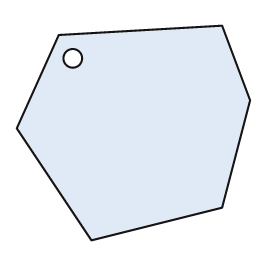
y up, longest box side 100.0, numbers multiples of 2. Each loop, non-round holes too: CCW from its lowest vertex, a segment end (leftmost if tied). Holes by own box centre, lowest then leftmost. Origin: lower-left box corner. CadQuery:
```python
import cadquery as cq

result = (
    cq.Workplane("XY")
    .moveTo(32.0, 0.0)
    .lineTo(88.0, 14.0)
    .lineTo(100.0, 60.0)
    .lineTo(88.0, 92.0)
    .lineTo(18.0, 88.0)
    .lineTo(0.0, 48.0)
    .close()
    .moveTo(24.0, 78.0)
    .circle(4.0)
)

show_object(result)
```